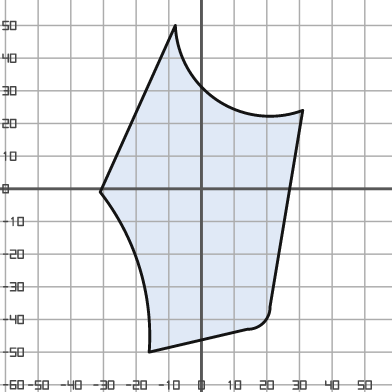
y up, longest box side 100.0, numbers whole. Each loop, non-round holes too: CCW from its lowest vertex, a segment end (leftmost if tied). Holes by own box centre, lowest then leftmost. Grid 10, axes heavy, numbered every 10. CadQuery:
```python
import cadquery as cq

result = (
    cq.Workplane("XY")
    .moveTo(-16.0, -50.0)
    .lineTo(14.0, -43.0)
    .threePointArc((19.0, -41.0), (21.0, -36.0))
    .lineTo(31.0, 24.0)
    .threePointArc((5.0, 27.0), (-8.0, 50.0))
    .lineTo(-31.0, -1.0)
    .threePointArc((-19.0, -24.0), (-16.0, -50.0))
    .close()
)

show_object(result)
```